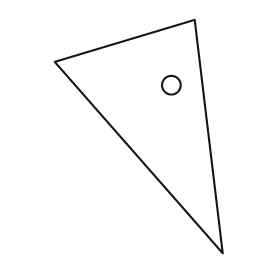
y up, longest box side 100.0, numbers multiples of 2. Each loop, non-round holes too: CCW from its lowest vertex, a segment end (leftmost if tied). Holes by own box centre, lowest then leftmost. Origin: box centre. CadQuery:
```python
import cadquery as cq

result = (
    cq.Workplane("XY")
    .moveTo(36.0, -50.0)
    .lineTo(24.0, 50.0)
    .lineTo(-36.0, 32.0)
    .close()
    .moveTo(14.0, 22.0)
    .circle(4.0)
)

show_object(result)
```